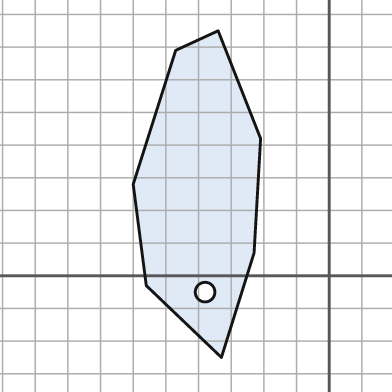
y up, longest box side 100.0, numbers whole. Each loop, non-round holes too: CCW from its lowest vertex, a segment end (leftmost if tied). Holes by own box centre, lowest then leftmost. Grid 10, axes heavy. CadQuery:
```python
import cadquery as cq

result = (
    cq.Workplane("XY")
    .moveTo(-33.0, -25.0)
    .lineTo(-23.0, 7.0)
    .lineTo(-21.0, 42.0)
    .lineTo(-34.0, 75.0)
    .lineTo(-47.0, 69.0)
    .lineTo(-60.0, 28.0)
    .lineTo(-56.0, -3.0)
    .close()
    .moveTo(-38.0, -5.0)
    .circle(3.0)
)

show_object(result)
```